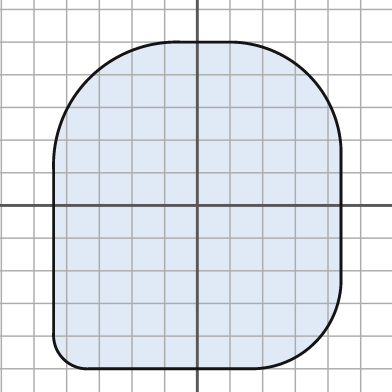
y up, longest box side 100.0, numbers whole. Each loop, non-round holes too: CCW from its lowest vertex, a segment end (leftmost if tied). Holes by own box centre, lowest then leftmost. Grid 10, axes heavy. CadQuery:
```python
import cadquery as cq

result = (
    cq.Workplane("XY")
    .moveTo(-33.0, -50.0)
    .lineTo(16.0, -50.0)
    .threePointArc((36.0, -42.0), (44.0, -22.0))
    .lineTo(44.0, 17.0)
    .threePointArc((34.0, 40.0), (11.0, 50.0))
    .lineTo(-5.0, 50.0)
    .threePointArc((-33.0, 39.0), (-44.0, 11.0))
    .lineTo(-44.0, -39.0)
    .threePointArc((-41.0, -47.0), (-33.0, -50.0))
    .close()
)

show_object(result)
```